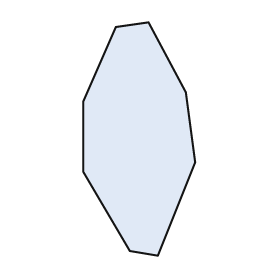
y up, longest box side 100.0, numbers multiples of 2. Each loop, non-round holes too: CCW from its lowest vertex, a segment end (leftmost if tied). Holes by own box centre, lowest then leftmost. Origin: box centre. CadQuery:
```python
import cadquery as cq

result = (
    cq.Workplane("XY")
    .moveTo(8.0, -50.0)
    .lineTo(24.0, -10.0)
    .lineTo(20.0, 20.0)
    .lineTo(4.0, 50.0)
    .lineTo(-10.0, 48.0)
    .lineTo(-24.0, 16.0)
    .lineTo(-24.0, -14.0)
    .lineTo(-4.0, -48.0)
    .close()
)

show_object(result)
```